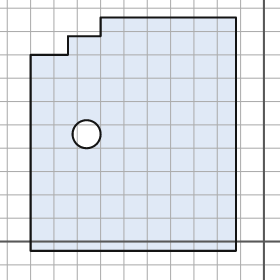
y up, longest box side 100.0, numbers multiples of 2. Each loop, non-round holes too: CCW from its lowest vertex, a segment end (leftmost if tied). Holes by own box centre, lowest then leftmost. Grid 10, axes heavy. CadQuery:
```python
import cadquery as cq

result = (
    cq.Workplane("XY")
    .moveTo(-100.0, -4.0)
    .lineTo(-12.0, -4.0)
    .lineTo(-12.0, 96.0)
    .lineTo(-70.0, 96.0)
    .lineTo(-70.0, 88.0)
    .lineTo(-84.0, 88.0)
    .lineTo(-84.0, 80.0)
    .lineTo(-100.0, 80.0)
    .close()
    .moveTo(-76.0, 46.0)
    .circle(6.0)
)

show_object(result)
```